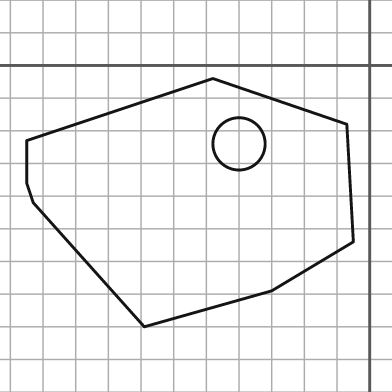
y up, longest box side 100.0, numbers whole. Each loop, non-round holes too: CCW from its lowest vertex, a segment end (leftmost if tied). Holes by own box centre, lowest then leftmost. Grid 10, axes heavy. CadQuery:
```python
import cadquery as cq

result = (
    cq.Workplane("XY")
    .moveTo(-69.0, -80.0)
    .lineTo(-30.0, -69.0)
    .lineTo(-5.0, -54.0)
    .lineTo(-7.0, -18.0)
    .lineTo(-48.0, -4.0)
    .lineTo(-105.0, -23.0)
    .lineTo(-105.0, -36.0)
    .lineTo(-103.0, -42.0)
    .close()
    .moveTo(-40.0, -24.0)
    .circle(8.0)
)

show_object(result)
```